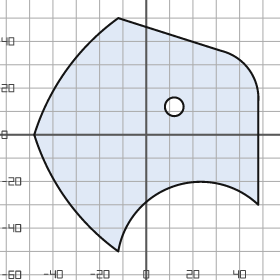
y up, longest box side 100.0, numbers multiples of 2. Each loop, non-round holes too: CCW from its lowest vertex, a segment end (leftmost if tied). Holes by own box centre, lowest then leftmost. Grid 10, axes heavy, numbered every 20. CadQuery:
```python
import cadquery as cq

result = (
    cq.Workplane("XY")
    .moveTo(-12.0, -50.0)
    .threePointArc((12.0, -22.0), (48.0, -30.0))
    .lineTo(48.0, 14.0)
    .threePointArc((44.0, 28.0), (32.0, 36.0))
    .lineTo(-12.0, 50.0)
    .threePointArc((-34.0, 28.0), (-48.0, 0.0))
    .threePointArc((-34.0, -28.0), (-12.0, -50.0))
    .close()
    .moveTo(12.0, 12.0)
    .circle(4.0)
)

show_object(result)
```